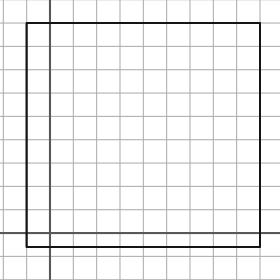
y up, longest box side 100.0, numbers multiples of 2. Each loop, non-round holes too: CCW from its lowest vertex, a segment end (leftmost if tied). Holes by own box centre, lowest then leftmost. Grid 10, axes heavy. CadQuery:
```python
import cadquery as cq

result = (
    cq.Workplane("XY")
    .moveTo(-10.0, -6.0)
    .lineTo(90.0, -6.0)
    .lineTo(90.0, 90.0)
    .lineTo(-10.0, 90.0)
    .close()
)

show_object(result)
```